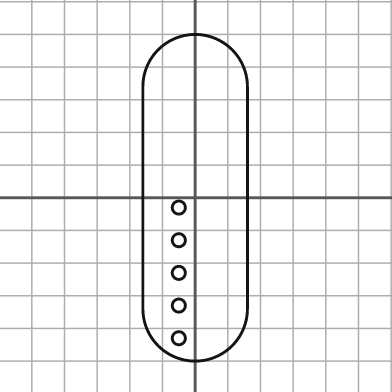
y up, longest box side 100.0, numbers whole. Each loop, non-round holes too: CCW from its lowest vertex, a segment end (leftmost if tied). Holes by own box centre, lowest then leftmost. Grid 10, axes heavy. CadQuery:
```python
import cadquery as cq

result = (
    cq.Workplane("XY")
    .moveTo(-16.0, -34.0)
    .threePointArc((0.0, -50.0), (16.0, -34.0))
    .lineTo(16.0, 34.0)
    .threePointArc((0.0, 50.0), (-16.0, 34.0))
    .close()
    .moveTo(-5.0, -43.0)
    .circle(2.0)
    .moveTo(-5.0, -33.0)
    .circle(2.0)
    .moveTo(-5.0, -23.0)
    .circle(2.0)
    .moveTo(-5.0, -13.0)
    .circle(2.0)
    .moveTo(-5.0, -3.0)
    .circle(2.0)
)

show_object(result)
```